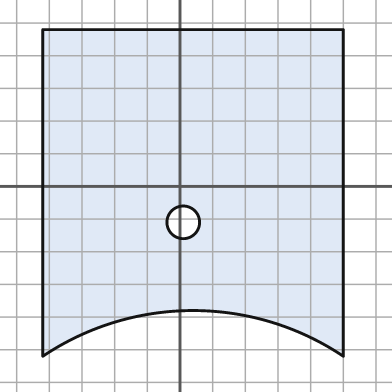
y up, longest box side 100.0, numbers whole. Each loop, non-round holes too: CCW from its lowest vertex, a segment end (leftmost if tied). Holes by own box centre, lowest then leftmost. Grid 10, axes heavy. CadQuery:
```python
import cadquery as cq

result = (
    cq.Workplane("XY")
    .moveTo(-42.0, -52.0)
    .threePointArc((4.0, -38.0), (50.0, -52.0))
    .lineTo(50.0, 48.0)
    .lineTo(-42.0, 48.0)
    .close()
    .moveTo(1.0, -11.0)
    .circle(5.0)
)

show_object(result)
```